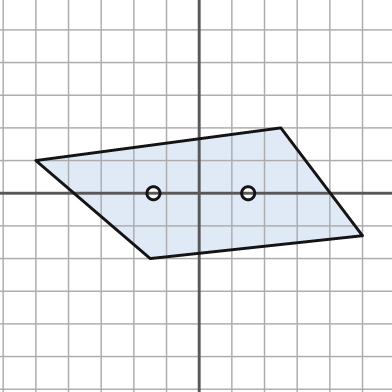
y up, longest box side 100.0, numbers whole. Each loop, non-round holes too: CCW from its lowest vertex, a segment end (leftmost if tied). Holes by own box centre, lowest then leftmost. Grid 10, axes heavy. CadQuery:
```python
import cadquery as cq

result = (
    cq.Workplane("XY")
    .moveTo(-15.0, -20.0)
    .lineTo(50.0, -13.0)
    .lineTo(25.0, 20.0)
    .lineTo(-50.0, 10.0)
    .close()
    .moveTo(-14.0, 0.0)
    .circle(2.0)
    .moveTo(15.0, 0.0)
    .circle(2.0)
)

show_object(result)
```